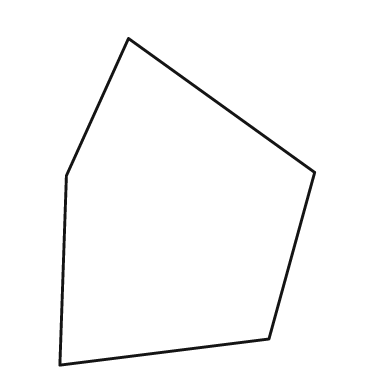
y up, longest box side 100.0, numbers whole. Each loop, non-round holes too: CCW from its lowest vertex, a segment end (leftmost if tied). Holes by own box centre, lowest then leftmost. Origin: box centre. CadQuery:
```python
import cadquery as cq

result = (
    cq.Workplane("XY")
    .moveTo(-39.0, -50.0)
    .lineTo(25.0, -42.0)
    .lineTo(39.0, 9.0)
    .lineTo(-18.0, 50.0)
    .lineTo(-37.0, 8.0)
    .close()
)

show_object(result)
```